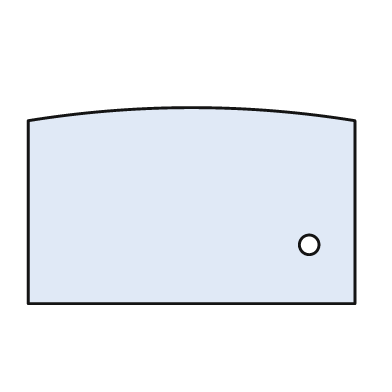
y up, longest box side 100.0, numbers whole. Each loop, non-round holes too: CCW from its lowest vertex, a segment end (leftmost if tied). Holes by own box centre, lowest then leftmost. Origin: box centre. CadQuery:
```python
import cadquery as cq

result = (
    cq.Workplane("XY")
    .moveTo(-50.0, -30.0)
    .lineTo(50.0, -30.0)
    .lineTo(50.0, 26.0)
    .threePointArc((0.0, 30.0), (-50.0, 26.0))
    .close()
    .moveTo(36.0, -12.0)
    .circle(3.0)
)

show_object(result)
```